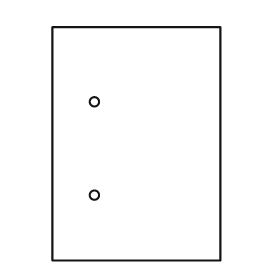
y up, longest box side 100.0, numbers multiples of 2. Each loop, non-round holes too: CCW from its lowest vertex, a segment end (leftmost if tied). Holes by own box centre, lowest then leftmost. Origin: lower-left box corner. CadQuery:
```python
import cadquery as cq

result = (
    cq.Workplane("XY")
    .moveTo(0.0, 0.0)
    .lineTo(72.0, 0.0)
    .lineTo(72.0, 100.0)
    .lineTo(0.0, 100.0)
    .close()
    .moveTo(18.0, 28.0)
    .circle(2.0)
    .moveTo(18.0, 68.0)
    .circle(2.0)
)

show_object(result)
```